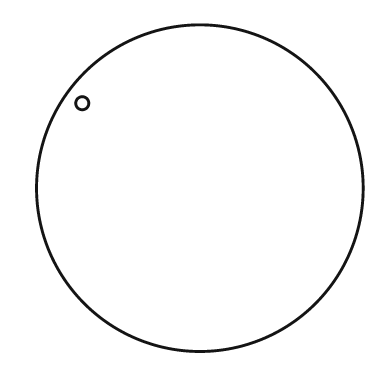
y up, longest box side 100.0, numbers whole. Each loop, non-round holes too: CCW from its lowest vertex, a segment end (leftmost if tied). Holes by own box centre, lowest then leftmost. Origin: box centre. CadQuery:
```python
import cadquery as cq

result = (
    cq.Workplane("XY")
    .moveTo(0.0, 0.0)
    .circle(50.0)
    .moveTo(-36.0, 26.0)
    .circle(2.0)
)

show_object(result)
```